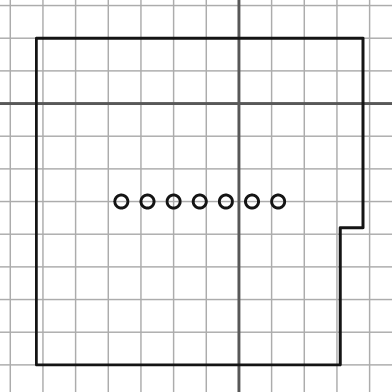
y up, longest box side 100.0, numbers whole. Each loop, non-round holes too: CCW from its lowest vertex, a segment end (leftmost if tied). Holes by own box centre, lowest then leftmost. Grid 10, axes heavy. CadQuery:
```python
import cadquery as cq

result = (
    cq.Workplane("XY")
    .moveTo(-62.0, -80.0)
    .lineTo(31.0, -80.0)
    .lineTo(31.0, -38.0)
    .lineTo(38.0, -38.0)
    .lineTo(38.0, 20.0)
    .lineTo(-62.0, 20.0)
    .close()
    .moveTo(-36.0, -30.0)
    .circle(2.0)
    .moveTo(-28.0, -30.0)
    .circle(2.0)
    .moveTo(-20.0, -30.0)
    .circle(2.0)
    .moveTo(-12.0, -30.0)
    .circle(2.0)
    .moveTo(-4.0, -30.0)
    .circle(2.0)
    .moveTo(4.0, -30.0)
    .circle(2.0)
    .moveTo(12.0, -30.0)
    .circle(2.0)
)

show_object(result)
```